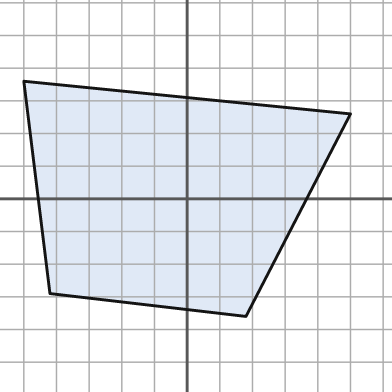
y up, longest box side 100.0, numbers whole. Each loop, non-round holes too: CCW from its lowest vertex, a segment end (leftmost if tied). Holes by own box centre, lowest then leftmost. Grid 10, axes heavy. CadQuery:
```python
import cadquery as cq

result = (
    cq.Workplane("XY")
    .moveTo(18.0, -36.0)
    .lineTo(50.0, 26.0)
    .lineTo(-50.0, 36.0)
    .lineTo(-42.0, -29.0)
    .close()
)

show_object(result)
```